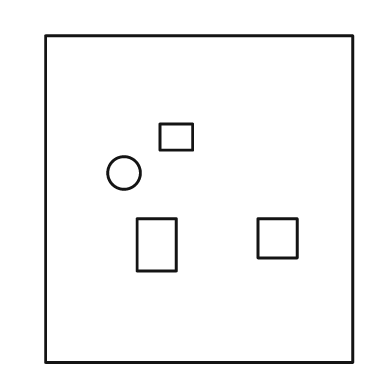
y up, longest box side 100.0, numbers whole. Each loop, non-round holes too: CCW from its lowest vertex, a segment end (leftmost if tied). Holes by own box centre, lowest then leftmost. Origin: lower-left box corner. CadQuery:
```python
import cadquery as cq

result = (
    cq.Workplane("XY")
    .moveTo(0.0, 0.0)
    .lineTo(94.0, 0.0)
    .lineTo(94.0, 100.0)
    .lineTo(0.0, 100.0)
    .close()
    .moveTo(28.0, 28.0)
    .lineTo(40.0, 28.0)
    .lineTo(40.0, 44.0)
    .lineTo(28.0, 44.0)
    .close()
    .moveTo(65.0, 32.0)
    .lineTo(77.0, 32.0)
    .lineTo(77.0, 44.0)
    .lineTo(65.0, 44.0)
    .close()
    .moveTo(24.0, 58.0)
    .circle(5.0)
    .moveTo(35.0, 65.0)
    .lineTo(45.0, 65.0)
    .lineTo(45.0, 73.0)
    .lineTo(35.0, 73.0)
    .close()
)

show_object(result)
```